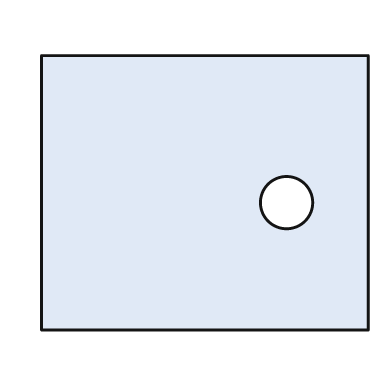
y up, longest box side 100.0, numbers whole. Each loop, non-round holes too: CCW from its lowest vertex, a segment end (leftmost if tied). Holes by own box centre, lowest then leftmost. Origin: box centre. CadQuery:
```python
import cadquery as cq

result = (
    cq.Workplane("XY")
    .moveTo(-50.0, -42.0)
    .lineTo(50.0, -42.0)
    .lineTo(50.0, 42.0)
    .lineTo(-50.0, 42.0)
    .close()
    .moveTo(25.0, -3.0)
    .circle(8.0)
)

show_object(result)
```